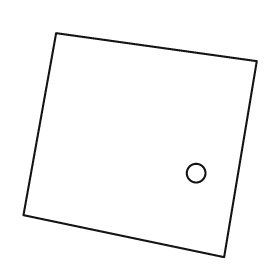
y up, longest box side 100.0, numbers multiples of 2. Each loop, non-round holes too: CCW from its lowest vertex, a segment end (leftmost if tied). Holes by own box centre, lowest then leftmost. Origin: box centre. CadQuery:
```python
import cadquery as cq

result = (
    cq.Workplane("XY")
    .moveTo(36.0, -48.0)
    .lineTo(50.0, 36.0)
    .lineTo(-36.0, 48.0)
    .lineTo(-50.0, -30.0)
    .close()
    .moveTo(24.0, -12.0)
    .circle(4.0)
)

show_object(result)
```